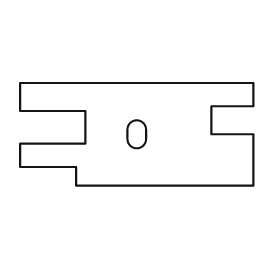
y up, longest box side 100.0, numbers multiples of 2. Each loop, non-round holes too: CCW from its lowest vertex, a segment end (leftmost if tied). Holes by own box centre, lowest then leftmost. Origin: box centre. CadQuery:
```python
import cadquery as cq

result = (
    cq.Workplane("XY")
    .moveTo(-26.0, -22.0)
    .lineTo(50.0, -22.0)
    .lineTo(50.0, 0.0)
    .lineTo(32.0, 0.0)
    .lineTo(32.0, 12.0)
    .lineTo(50.0, 12.0)
    .lineTo(50.0, 22.0)
    .lineTo(-50.0, 22.0)
    .lineTo(-50.0, 10.0)
    .lineTo(-22.0, 10.0)
    .lineTo(-22.0, -4.0)
    .lineTo(-50.0, -4.0)
    .lineTo(-50.0, -14.0)
    .lineTo(-26.0, -14.0)
    .close()
    .moveTo(-4.0, -2.0)
    .threePointArc((0.0, -6.0), (4.0, -2.0))
    .lineTo(4.0, 2.0)
    .threePointArc((0.0, 6.0), (-4.0, 2.0))
    .close()
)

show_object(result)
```